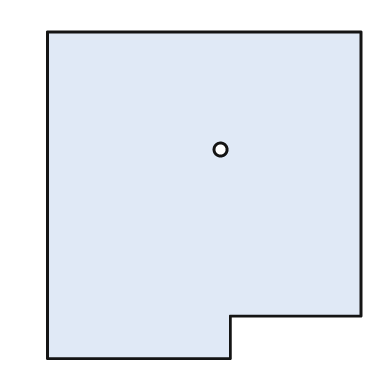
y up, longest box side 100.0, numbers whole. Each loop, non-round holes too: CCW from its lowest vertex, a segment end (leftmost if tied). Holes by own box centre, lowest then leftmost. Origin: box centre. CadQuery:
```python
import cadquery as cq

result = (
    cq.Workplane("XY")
    .moveTo(-48.0, -50.0)
    .lineTo(8.0, -50.0)
    .lineTo(8.0, -37.0)
    .lineTo(48.0, -37.0)
    .lineTo(48.0, 50.0)
    .lineTo(-48.0, 50.0)
    .close()
    .moveTo(5.0, 14.0)
    .circle(2.0)
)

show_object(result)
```